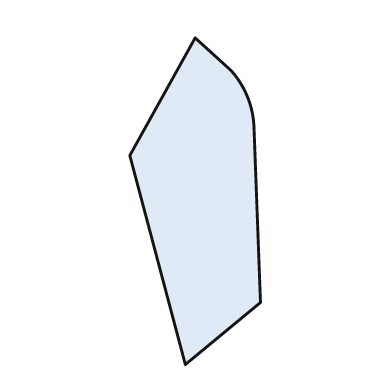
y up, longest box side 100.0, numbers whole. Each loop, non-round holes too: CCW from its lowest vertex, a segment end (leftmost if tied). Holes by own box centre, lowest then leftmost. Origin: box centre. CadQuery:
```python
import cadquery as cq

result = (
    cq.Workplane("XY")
    .moveTo(-3.0, -50.0)
    .lineTo(20.0, -31.0)
    .lineTo(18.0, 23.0)
    .threePointArc((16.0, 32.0), (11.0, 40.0))
    .lineTo(0.0, 50.0)
    .lineTo(-20.0, 14.0)
    .close()
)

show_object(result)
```